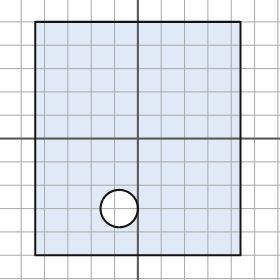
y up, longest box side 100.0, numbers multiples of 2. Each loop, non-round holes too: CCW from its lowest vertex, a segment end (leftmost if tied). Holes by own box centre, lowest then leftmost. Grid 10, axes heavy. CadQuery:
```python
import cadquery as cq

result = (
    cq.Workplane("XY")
    .moveTo(-44.0, -50.0)
    .lineTo(44.0, -50.0)
    .lineTo(44.0, 50.0)
    .lineTo(-44.0, 50.0)
    .close()
    .moveTo(-8.0, -30.0)
    .circle(8.0)
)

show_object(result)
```